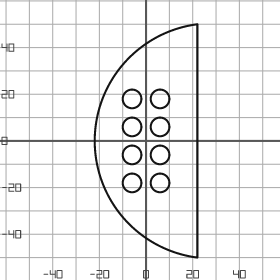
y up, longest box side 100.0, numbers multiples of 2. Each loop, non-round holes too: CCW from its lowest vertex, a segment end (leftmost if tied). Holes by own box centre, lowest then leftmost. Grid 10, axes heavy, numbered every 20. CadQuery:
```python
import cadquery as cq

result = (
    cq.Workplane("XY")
    .moveTo(22.0, -50.0)
    .lineTo(22.0, 50.0)
    .threePointArc((-22.0, 0.0), (22.0, -50.0))
    .close()
    .moveTo(-6.0, -18.0)
    .circle(4.0)
    .moveTo(6.0, -18.0)
    .circle(4.0)
    .moveTo(-6.0, -6.0)
    .circle(4.0)
    .moveTo(6.0, -6.0)
    .circle(4.0)
    .moveTo(-6.0, 6.0)
    .circle(4.0)
    .moveTo(6.0, 6.0)
    .circle(4.0)
    .moveTo(-6.0, 18.0)
    .circle(4.0)
    .moveTo(6.0, 18.0)
    .circle(4.0)
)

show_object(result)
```